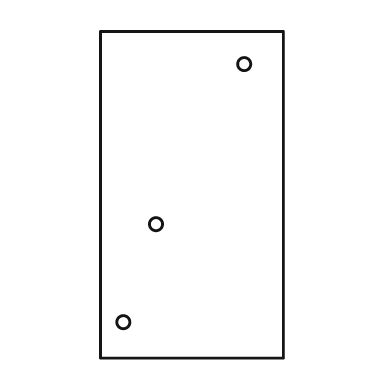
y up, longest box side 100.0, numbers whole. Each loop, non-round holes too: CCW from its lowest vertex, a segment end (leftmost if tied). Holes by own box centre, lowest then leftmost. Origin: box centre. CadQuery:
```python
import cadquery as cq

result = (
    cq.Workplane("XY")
    .moveTo(-28.0, -50.0)
    .lineTo(28.0, -50.0)
    .lineTo(28.0, 50.0)
    .lineTo(-28.0, 50.0)
    .close()
    .moveTo(-21.0, -39.0)
    .circle(2.0)
    .moveTo(-11.0, -9.0)
    .circle(2.0)
    .moveTo(16.0, 40.0)
    .circle(2.0)
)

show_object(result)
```